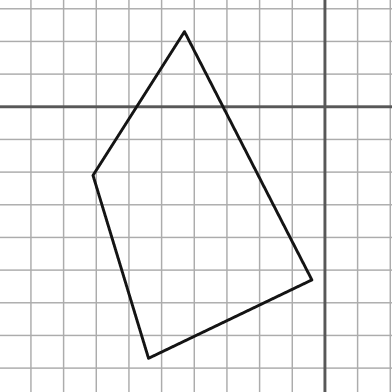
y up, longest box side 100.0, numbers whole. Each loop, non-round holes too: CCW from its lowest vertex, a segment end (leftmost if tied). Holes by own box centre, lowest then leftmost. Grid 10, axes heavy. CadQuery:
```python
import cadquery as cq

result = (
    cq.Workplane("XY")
    .moveTo(-54.0, -77.0)
    .lineTo(-4.0, -53.0)
    .lineTo(-43.0, 23.0)
    .lineTo(-71.0, -21.0)
    .close()
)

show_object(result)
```